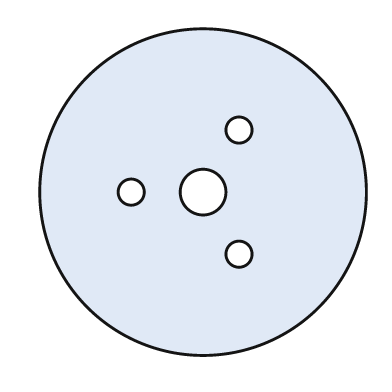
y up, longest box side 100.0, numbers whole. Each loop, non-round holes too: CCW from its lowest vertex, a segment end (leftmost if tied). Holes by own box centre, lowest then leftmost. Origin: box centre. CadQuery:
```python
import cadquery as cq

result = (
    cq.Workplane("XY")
    .moveTo(0.0, 0.0)
    .circle(50.0)
    .moveTo(11.0, -19.0)
    .circle(4.0)
    .moveTo(-22.0, 0.0)
    .circle(4.0)
    .moveTo(0.0, 0.0)
    .circle(7.0)
    .moveTo(11.0, 19.0)
    .circle(4.0)
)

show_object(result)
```